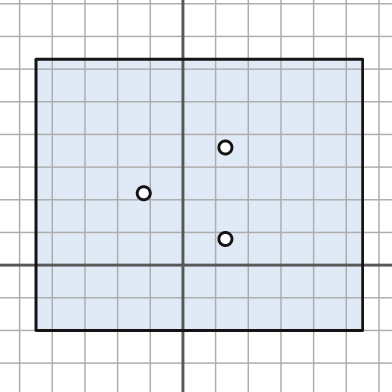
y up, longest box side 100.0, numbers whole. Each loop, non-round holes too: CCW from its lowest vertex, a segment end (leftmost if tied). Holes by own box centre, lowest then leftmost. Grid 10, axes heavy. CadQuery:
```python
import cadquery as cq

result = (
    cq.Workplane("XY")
    .moveTo(-45.0, -20.0)
    .lineTo(55.0, -20.0)
    .lineTo(55.0, 63.0)
    .lineTo(-45.0, 63.0)
    .close()
    .moveTo(13.0, 8.0)
    .circle(2.0)
    .moveTo(-12.0, 22.0)
    .circle(2.0)
    .moveTo(13.0, 36.0)
    .circle(2.0)
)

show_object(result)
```